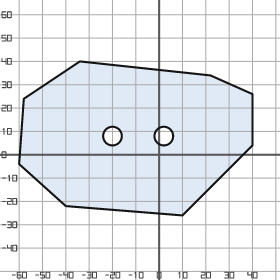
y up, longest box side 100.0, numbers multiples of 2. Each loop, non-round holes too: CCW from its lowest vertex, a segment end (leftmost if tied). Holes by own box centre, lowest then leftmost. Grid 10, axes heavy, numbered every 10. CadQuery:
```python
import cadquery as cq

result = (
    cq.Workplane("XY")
    .moveTo(10.0, -26.0)
    .lineTo(40.0, 4.0)
    .lineTo(40.0, 26.0)
    .lineTo(22.0, 34.0)
    .lineTo(-34.0, 40.0)
    .lineTo(-58.0, 24.0)
    .lineTo(-60.0, -4.0)
    .lineTo(-40.0, -22.0)
    .close()
    .moveTo(-20.0, 8.0)
    .circle(4.0)
    .moveTo(2.0, 8.0)
    .circle(4.0)
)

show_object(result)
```